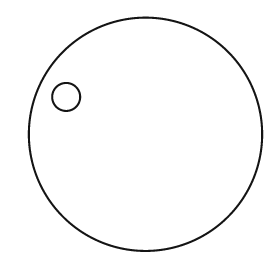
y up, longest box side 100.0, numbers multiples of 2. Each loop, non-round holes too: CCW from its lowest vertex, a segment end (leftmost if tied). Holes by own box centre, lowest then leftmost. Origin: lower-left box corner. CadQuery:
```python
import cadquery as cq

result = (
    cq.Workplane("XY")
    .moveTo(50.0, 50.0)
    .circle(50.0)
    .moveTo(16.0, 66.0)
    .circle(6.0)
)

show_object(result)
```